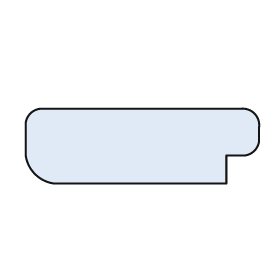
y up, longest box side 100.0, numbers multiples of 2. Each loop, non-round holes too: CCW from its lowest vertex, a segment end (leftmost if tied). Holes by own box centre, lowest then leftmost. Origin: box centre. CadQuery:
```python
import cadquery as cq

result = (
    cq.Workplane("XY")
    .moveTo(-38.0, -16.0)
    .lineTo(36.0, -16.0)
    .lineTo(36.0, -4.0)
    .lineTo(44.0, -4.0)
    .threePointArc((48.0, -2.0), (50.0, 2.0))
    .lineTo(50.0, 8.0)
    .threePointArc((48.0, 14.0), (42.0, 16.0))
    .lineTo(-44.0, 16.0)
    .threePointArc((-48.0, 14.0), (-50.0, 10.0))
    .lineTo(-50.0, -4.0)
    .threePointArc((-46.0, -12.0), (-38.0, -16.0))
    .close()
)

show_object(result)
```